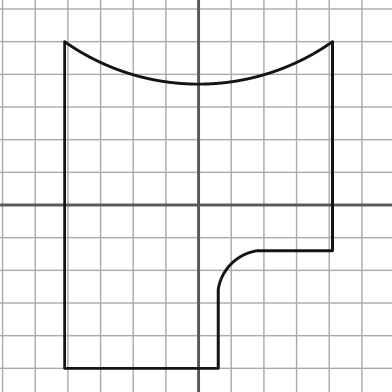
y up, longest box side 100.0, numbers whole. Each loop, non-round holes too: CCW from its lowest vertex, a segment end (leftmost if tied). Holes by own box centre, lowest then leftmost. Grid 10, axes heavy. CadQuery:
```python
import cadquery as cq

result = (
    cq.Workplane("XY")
    .moveTo(-41.0, -50.0)
    .lineTo(6.0, -50.0)
    .lineTo(6.0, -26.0)
    .threePointArc((10.0, -18.0), (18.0, -14.0))
    .lineTo(41.0, -14.0)
    .lineTo(41.0, 50.0)
    .threePointArc((0.0, 37.0), (-41.0, 50.0))
    .close()
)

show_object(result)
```